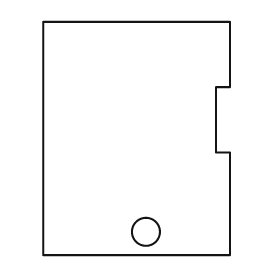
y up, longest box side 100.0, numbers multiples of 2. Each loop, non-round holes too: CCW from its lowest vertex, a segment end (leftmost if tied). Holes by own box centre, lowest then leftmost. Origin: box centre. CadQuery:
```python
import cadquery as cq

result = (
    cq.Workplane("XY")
    .moveTo(-40.0, -50.0)
    .lineTo(40.0, -50.0)
    .lineTo(40.0, -6.0)
    .lineTo(34.0, -6.0)
    .lineTo(34.0, 22.0)
    .lineTo(40.0, 22.0)
    .lineTo(40.0, 50.0)
    .lineTo(-40.0, 50.0)
    .close()
    .moveTo(4.0, -40.0)
    .circle(6.0)
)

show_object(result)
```